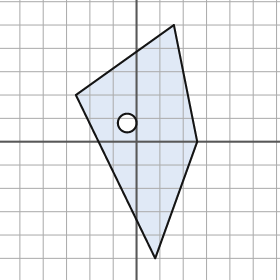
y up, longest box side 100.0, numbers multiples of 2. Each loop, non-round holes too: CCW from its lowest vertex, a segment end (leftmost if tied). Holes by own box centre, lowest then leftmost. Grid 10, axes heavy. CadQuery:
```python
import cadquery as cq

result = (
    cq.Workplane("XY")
    .moveTo(8.0, -50.0)
    .lineTo(26.0, 0.0)
    .lineTo(16.0, 50.0)
    .lineTo(-26.0, 20.0)
    .close()
    .moveTo(-4.0, 8.0)
    .circle(4.0)
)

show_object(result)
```